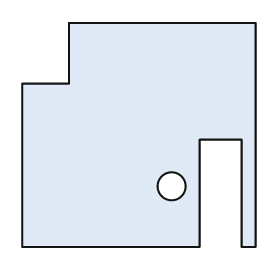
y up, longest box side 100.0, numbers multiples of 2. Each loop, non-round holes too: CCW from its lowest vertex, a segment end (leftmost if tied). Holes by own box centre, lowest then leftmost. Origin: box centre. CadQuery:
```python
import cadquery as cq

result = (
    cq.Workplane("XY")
    .moveTo(-50.0, -48.0)
    .lineTo(26.0, -48.0)
    .lineTo(26.0, -2.0)
    .lineTo(44.0, -2.0)
    .lineTo(44.0, -48.0)
    .lineTo(50.0, -48.0)
    .lineTo(50.0, 48.0)
    .lineTo(-30.0, 48.0)
    .lineTo(-30.0, 22.0)
    .lineTo(-50.0, 22.0)
    .close()
    .moveTo(14.0, -22.0)
    .circle(6.0)
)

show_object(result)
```